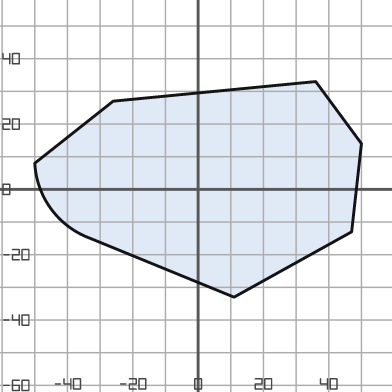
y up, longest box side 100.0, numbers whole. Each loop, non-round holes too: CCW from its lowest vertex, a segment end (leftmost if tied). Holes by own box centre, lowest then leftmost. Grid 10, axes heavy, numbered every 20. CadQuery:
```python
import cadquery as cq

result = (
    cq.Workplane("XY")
    .moveTo(11.0, -33.0)
    .lineTo(47.0, -13.0)
    .lineTo(50.0, 14.0)
    .lineTo(36.0, 33.0)
    .lineTo(-26.0, 27.0)
    .lineTo(-50.0, 8.0)
    .threePointArc((-45.0, -6.0), (-33.0, -15.0))
    .close()
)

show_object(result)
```